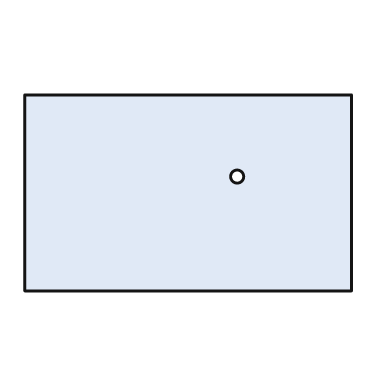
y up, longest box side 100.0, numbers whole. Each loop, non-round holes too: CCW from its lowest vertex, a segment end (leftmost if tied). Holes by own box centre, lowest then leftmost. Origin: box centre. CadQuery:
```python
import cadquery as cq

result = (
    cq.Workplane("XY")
    .moveTo(-50.0, -30.0)
    .lineTo(50.0, -30.0)
    .lineTo(50.0, 30.0)
    .lineTo(-50.0, 30.0)
    .close()
    .moveTo(15.0, 5.0)
    .circle(2.0)
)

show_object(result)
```